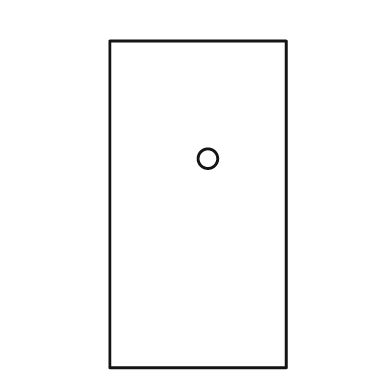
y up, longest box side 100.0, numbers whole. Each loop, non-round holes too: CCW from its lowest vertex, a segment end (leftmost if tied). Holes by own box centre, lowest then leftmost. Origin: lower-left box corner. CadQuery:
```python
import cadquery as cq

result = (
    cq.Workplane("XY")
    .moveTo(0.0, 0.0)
    .lineTo(54.0, 0.0)
    .lineTo(54.0, 100.0)
    .lineTo(0.0, 100.0)
    .close()
    .moveTo(30.0, 64.0)
    .circle(3.0)
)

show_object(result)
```